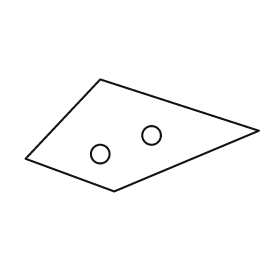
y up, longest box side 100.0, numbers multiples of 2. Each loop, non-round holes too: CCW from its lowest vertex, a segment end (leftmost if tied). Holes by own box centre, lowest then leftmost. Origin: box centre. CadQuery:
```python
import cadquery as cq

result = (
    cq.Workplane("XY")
    .moveTo(-12.0, -24.0)
    .lineTo(50.0, 2.0)
    .lineTo(-18.0, 24.0)
    .lineTo(-50.0, -10.0)
    .close()
    .moveTo(-18.0, -8.0)
    .circle(4.0)
    .moveTo(4.0, 0.0)
    .circle(4.0)
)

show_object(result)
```